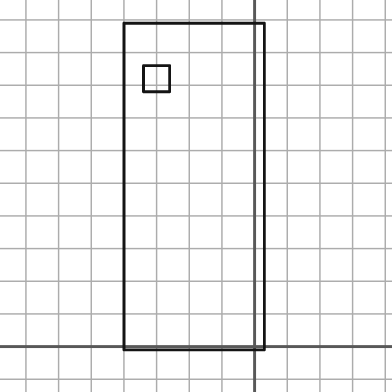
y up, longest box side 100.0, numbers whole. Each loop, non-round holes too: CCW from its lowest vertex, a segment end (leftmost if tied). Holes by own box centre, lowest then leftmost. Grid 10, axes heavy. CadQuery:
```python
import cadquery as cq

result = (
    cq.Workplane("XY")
    .moveTo(-40.0, -1.0)
    .lineTo(3.0, -1.0)
    .lineTo(3.0, 99.0)
    .lineTo(-40.0, 99.0)
    .close()
    .moveTo(-34.0, 78.0)
    .lineTo(-26.0, 78.0)
    .lineTo(-26.0, 86.0)
    .lineTo(-34.0, 86.0)
    .close()
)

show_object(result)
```